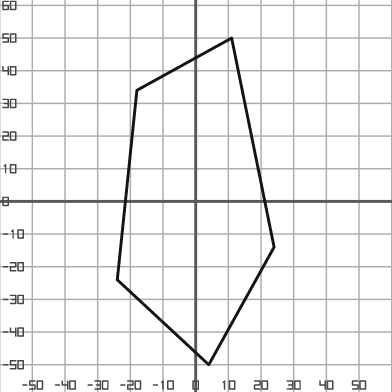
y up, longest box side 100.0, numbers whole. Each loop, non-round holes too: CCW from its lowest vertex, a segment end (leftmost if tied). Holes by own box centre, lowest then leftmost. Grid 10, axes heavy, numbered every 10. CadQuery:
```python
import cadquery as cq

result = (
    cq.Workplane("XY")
    .moveTo(4.0, -50.0)
    .lineTo(24.0, -14.0)
    .lineTo(11.0, 50.0)
    .lineTo(-18.0, 34.0)
    .lineTo(-24.0, -24.0)
    .close()
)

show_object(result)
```